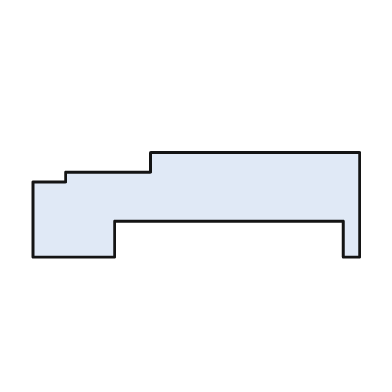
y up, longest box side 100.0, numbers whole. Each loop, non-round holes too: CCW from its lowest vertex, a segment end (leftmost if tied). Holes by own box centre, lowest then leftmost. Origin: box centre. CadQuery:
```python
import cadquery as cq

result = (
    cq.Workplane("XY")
    .moveTo(-50.0, -16.0)
    .lineTo(-25.0, -16.0)
    .lineTo(-25.0, -5.0)
    .lineTo(45.0, -5.0)
    .lineTo(45.0, -16.0)
    .lineTo(50.0, -16.0)
    .lineTo(50.0, 16.0)
    .lineTo(-14.0, 16.0)
    .lineTo(-14.0, 10.0)
    .lineTo(-40.0, 10.0)
    .lineTo(-40.0, 7.0)
    .lineTo(-50.0, 7.0)
    .close()
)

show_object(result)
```